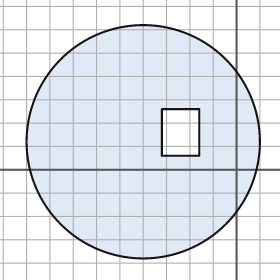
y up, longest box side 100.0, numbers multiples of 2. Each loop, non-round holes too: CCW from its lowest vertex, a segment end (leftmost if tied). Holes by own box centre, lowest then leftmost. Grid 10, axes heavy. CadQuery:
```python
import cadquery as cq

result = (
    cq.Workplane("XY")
    .moveTo(-40.0, 12.0)
    .circle(50.0)
    .moveTo(-32.0, 6.0)
    .lineTo(-16.0, 6.0)
    .lineTo(-16.0, 26.0)
    .lineTo(-32.0, 26.0)
    .close()
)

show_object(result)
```